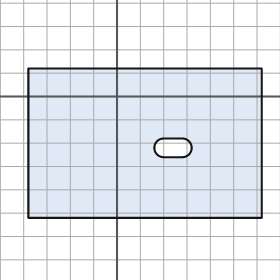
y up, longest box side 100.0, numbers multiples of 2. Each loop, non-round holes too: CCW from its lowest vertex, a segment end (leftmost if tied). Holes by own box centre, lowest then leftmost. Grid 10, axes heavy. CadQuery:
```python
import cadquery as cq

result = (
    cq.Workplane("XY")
    .moveTo(-38.0, -52.0)
    .lineTo(62.0, -52.0)
    .lineTo(62.0, 12.0)
    .lineTo(-38.0, 12.0)
    .close()
    .moveTo(20.0, -26.0)
    .lineTo(28.0, -26.0)
    .threePointArc((32.0, -22.0), (28.0, -18.0))
    .lineTo(20.0, -18.0)
    .threePointArc((16.0, -22.0), (20.0, -26.0))
    .close()
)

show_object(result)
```